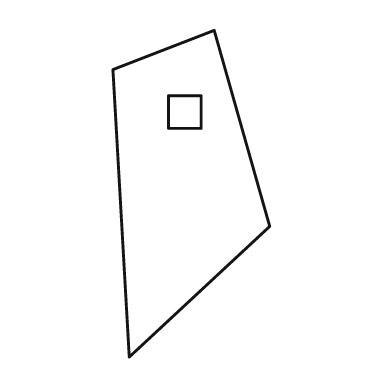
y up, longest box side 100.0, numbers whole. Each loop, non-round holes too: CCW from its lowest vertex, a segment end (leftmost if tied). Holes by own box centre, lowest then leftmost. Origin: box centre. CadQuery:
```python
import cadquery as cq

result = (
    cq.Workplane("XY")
    .moveTo(-19.0, -50.0)
    .lineTo(24.0, -10.0)
    .lineTo(7.0, 50.0)
    .lineTo(-24.0, 38.0)
    .close()
    .moveTo(-7.0, 20.0)
    .lineTo(3.0, 20.0)
    .lineTo(3.0, 30.0)
    .lineTo(-7.0, 30.0)
    .close()
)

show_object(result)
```